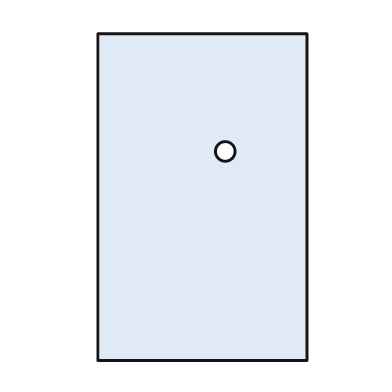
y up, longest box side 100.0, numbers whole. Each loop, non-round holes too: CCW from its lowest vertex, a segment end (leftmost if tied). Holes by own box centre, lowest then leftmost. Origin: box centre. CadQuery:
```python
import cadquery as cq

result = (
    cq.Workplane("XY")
    .moveTo(-32.0, -50.0)
    .lineTo(32.0, -50.0)
    .lineTo(32.0, 50.0)
    .lineTo(-32.0, 50.0)
    .close()
    .moveTo(7.0, 14.0)
    .circle(3.0)
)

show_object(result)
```